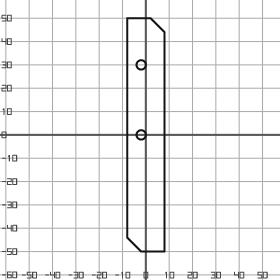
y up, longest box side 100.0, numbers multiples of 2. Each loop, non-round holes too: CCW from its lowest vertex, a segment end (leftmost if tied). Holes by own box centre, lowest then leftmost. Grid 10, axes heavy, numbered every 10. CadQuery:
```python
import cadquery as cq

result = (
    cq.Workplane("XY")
    .moveTo(-2.0, -50.0)
    .lineTo(8.0, -50.0)
    .lineTo(8.0, 44.0)
    .lineTo(2.0, 50.0)
    .lineTo(-8.0, 50.0)
    .lineTo(-8.0, -44.0)
    .close()
    .moveTo(-2.0, 0.0)
    .circle(2.0)
    .moveTo(-2.0, 30.0)
    .circle(2.0)
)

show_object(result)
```